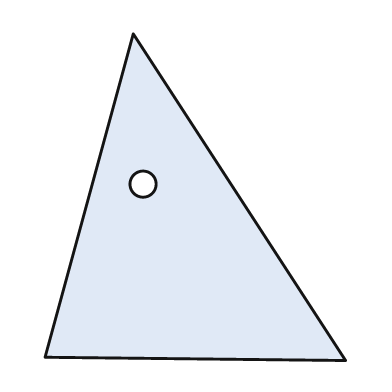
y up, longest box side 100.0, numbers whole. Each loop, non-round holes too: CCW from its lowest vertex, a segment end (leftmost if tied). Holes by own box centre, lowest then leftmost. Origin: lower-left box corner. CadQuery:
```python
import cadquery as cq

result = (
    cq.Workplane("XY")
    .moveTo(92.0, 0.0)
    .lineTo(27.0, 100.0)
    .lineTo(0.0, 1.0)
    .close()
    .moveTo(30.0, 54.0)
    .circle(4.0)
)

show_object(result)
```